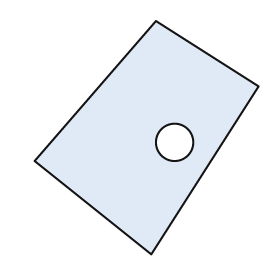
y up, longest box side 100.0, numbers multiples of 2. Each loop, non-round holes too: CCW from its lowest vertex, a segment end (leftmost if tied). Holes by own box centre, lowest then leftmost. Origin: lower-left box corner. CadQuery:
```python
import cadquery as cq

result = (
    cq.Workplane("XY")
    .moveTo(50.0, 0.0)
    .lineTo(96.0, 72.0)
    .lineTo(52.0, 100.0)
    .lineTo(0.0, 40.0)
    .close()
    .moveTo(60.0, 48.0)
    .circle(8.0)
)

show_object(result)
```